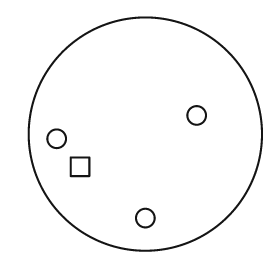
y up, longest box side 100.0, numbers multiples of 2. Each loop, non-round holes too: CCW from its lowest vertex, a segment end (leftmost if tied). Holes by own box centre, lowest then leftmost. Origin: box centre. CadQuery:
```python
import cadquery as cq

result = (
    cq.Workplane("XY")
    .moveTo(0.0, 0.0)
    .circle(50.0)
    .moveTo(0.0, -36.0)
    .circle(4.0)
    .moveTo(-32.0, -18.0)
    .lineTo(-24.0, -18.0)
    .lineTo(-24.0, -10.0)
    .lineTo(-32.0, -10.0)
    .close()
    .moveTo(-38.0, -2.0)
    .circle(4.0)
    .moveTo(22.0, 8.0)
    .circle(4.0)
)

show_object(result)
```